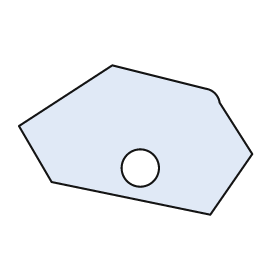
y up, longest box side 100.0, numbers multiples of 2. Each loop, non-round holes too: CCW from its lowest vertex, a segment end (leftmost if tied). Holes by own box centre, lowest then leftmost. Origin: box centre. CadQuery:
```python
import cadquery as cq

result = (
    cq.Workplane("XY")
    .moveTo(32.0, -32.0)
    .lineTo(50.0, -6.0)
    .lineTo(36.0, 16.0)
    .threePointArc((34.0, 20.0), (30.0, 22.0))
    .lineTo(-10.0, 32.0)
    .lineTo(-50.0, 6.0)
    .lineTo(-36.0, -18.0)
    .close()
    .moveTo(2.0, -12.0)
    .circle(8.0)
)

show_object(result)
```